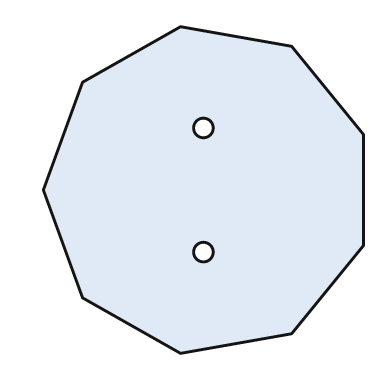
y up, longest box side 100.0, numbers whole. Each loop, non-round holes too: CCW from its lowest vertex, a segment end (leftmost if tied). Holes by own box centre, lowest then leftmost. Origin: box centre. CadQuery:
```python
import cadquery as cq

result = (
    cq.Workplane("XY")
    .moveTo(-7.0, -50.0)
    .lineTo(27.0, -44.0)
    .lineTo(49.0, -17.0)
    .lineTo(49.0, 17.0)
    .lineTo(27.0, 44.0)
    .lineTo(-7.0, 50.0)
    .lineTo(-37.0, 33.0)
    .lineTo(-49.0, 0.0)
    .lineTo(-37.0, -33.0)
    .close()
    .moveTo(0.0, -19.0)
    .circle(3.0)
    .moveTo(0.0, 19.0)
    .circle(3.0)
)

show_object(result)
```